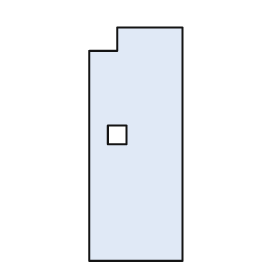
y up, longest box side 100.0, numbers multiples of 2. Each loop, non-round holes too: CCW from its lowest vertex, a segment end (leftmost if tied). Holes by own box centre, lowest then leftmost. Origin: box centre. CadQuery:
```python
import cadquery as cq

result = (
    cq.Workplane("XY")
    .moveTo(-20.0, -50.0)
    .lineTo(20.0, -50.0)
    .lineTo(20.0, 50.0)
    .lineTo(-8.0, 50.0)
    .lineTo(-8.0, 40.0)
    .lineTo(-20.0, 40.0)
    .close()
    .moveTo(-12.0, 0.0)
    .lineTo(-4.0, 0.0)
    .lineTo(-4.0, 8.0)
    .lineTo(-12.0, 8.0)
    .close()
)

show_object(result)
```